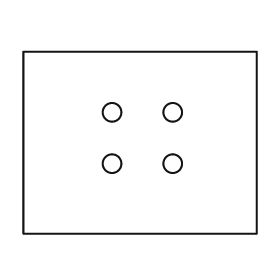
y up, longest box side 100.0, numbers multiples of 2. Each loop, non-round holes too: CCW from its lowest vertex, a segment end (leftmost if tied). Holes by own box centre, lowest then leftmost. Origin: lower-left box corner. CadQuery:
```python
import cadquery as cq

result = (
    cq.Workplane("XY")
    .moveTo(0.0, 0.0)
    .lineTo(100.0, 0.0)
    .lineTo(100.0, 78.0)
    .lineTo(0.0, 78.0)
    .close()
    .moveTo(38.0, 30.0)
    .circle(4.0)
    .moveTo(64.0, 30.0)
    .circle(4.0)
    .moveTo(38.0, 52.0)
    .circle(4.0)
    .moveTo(64.0, 52.0)
    .circle(4.0)
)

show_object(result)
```